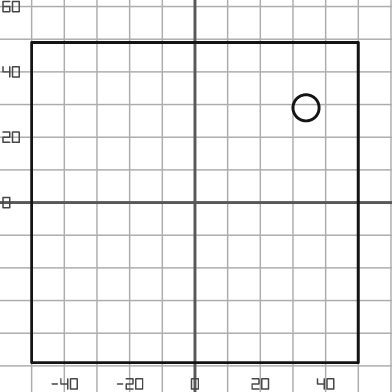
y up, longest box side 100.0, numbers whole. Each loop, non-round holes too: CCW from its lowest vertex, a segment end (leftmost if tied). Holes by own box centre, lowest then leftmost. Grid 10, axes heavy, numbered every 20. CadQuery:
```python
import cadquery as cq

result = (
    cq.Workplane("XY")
    .moveTo(-50.0, -49.0)
    .lineTo(50.0, -49.0)
    .lineTo(50.0, 49.0)
    .lineTo(-50.0, 49.0)
    .close()
    .moveTo(34.0, 29.0)
    .circle(4.0)
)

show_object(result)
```